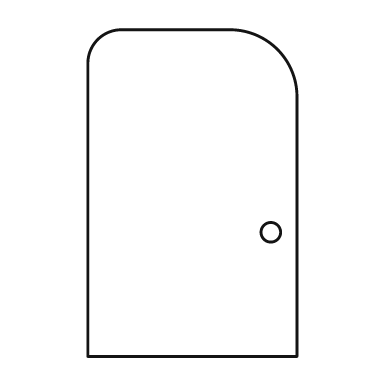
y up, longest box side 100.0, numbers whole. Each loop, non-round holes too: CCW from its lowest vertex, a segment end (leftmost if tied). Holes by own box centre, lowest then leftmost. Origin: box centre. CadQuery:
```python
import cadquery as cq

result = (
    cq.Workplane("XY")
    .moveTo(-32.0, -50.0)
    .lineTo(32.0, -50.0)
    .lineTo(32.0, 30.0)
    .threePointArc((26.0, 44.0), (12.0, 50.0))
    .lineTo(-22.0, 50.0)
    .threePointArc((-29.0, 47.0), (-32.0, 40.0))
    .close()
    .moveTo(24.0, -12.0)
    .circle(3.0)
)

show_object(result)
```